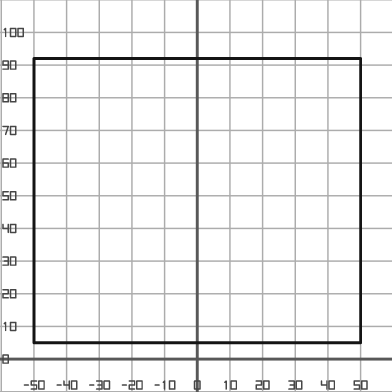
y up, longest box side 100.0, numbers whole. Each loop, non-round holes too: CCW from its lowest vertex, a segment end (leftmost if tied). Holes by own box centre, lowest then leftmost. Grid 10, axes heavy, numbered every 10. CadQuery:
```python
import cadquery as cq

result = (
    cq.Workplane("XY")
    .moveTo(-50.0, 5.0)
    .lineTo(50.0, 5.0)
    .lineTo(50.0, 92.0)
    .lineTo(-50.0, 92.0)
    .close()
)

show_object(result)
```